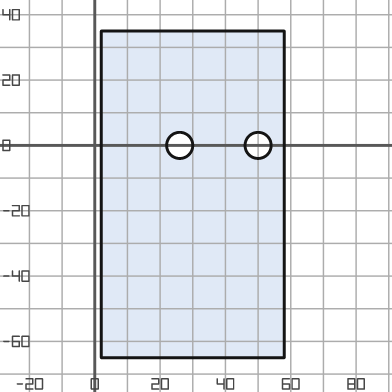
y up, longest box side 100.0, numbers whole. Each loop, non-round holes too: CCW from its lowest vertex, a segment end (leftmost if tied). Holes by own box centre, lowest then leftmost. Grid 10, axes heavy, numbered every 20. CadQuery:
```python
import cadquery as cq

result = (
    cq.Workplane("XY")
    .moveTo(2.0, -65.0)
    .lineTo(58.0, -65.0)
    .lineTo(58.0, 35.0)
    .lineTo(2.0, 35.0)
    .close()
    .moveTo(26.0, 0.0)
    .circle(4.0)
    .moveTo(50.0, 0.0)
    .circle(4.0)
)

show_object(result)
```